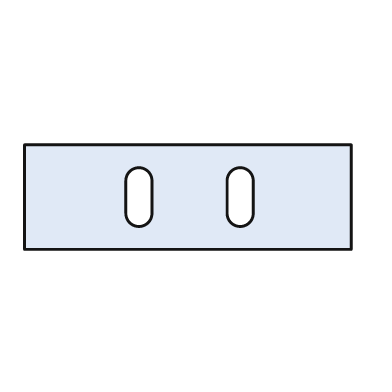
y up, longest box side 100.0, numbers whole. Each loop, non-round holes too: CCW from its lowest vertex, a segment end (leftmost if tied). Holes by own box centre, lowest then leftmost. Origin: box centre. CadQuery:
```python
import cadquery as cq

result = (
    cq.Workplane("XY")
    .moveTo(-50.0, -16.0)
    .lineTo(50.0, -16.0)
    .lineTo(50.0, 16.0)
    .lineTo(-50.0, 16.0)
    .close()
    .moveTo(-19.0, -5.0)
    .threePointArc((-15.0, -9.0), (-11.0, -5.0))
    .lineTo(-11.0, 5.0)
    .threePointArc((-15.0, 9.0), (-19.0, 5.0))
    .close()
    .moveTo(12.0, -5.0)
    .threePointArc((16.0, -9.0), (20.0, -5.0))
    .lineTo(20.0, 5.0)
    .threePointArc((16.0, 9.0), (12.0, 5.0))
    .close()
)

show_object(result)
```